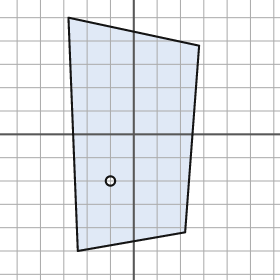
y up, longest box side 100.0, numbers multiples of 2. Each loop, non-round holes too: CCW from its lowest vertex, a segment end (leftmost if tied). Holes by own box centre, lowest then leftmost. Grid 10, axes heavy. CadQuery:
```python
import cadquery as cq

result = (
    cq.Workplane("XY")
    .moveTo(-24.0, -50.0)
    .lineTo(22.0, -42.0)
    .lineTo(28.0, 38.0)
    .lineTo(-28.0, 50.0)
    .close()
    .moveTo(-10.0, -20.0)
    .circle(2.0)
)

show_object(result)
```